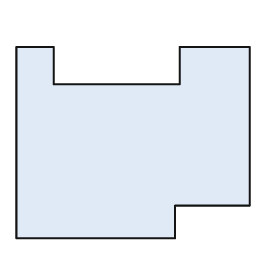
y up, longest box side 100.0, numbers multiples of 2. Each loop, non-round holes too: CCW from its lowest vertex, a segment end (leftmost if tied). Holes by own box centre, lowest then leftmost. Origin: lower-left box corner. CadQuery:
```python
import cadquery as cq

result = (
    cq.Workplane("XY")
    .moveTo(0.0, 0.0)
    .lineTo(68.0, 0.0)
    .lineTo(68.0, 14.0)
    .lineTo(100.0, 14.0)
    .lineTo(100.0, 82.0)
    .lineTo(70.0, 82.0)
    .lineTo(70.0, 66.0)
    .lineTo(16.0, 66.0)
    .lineTo(16.0, 82.0)
    .lineTo(0.0, 82.0)
    .close()
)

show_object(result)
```